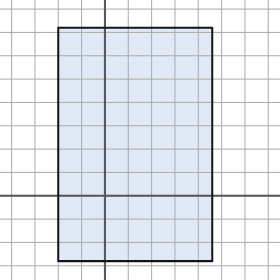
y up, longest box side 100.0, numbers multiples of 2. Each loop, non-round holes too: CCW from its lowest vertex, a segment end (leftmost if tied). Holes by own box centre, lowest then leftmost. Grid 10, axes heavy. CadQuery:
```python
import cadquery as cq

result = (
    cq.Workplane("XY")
    .moveTo(-20.0, -28.0)
    .lineTo(46.0, -28.0)
    .lineTo(46.0, 72.0)
    .lineTo(-20.0, 72.0)
    .close()
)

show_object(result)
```